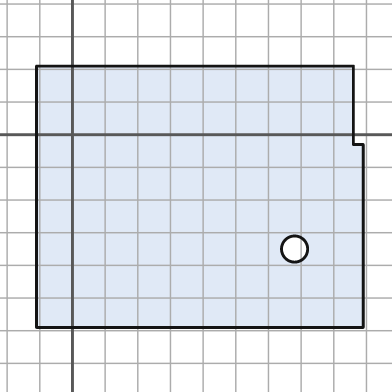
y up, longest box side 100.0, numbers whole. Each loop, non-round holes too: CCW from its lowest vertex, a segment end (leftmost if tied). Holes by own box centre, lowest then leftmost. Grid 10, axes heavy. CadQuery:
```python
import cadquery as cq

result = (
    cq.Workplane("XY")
    .moveTo(-11.0, -59.0)
    .lineTo(89.0, -59.0)
    .lineTo(89.0, -3.0)
    .lineTo(86.0, -3.0)
    .lineTo(86.0, 21.0)
    .lineTo(-11.0, 21.0)
    .close()
    .moveTo(68.0, -35.0)
    .circle(4.0)
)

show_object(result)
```